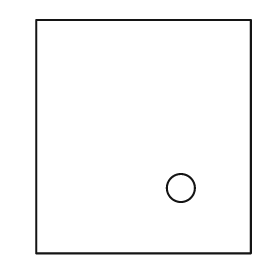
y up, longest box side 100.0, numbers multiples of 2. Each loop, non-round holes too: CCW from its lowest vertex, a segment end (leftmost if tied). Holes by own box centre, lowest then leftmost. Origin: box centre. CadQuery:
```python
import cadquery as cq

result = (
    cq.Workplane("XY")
    .moveTo(-46.0, -50.0)
    .lineTo(46.0, -50.0)
    .lineTo(46.0, 50.0)
    .lineTo(-46.0, 50.0)
    .close()
    .moveTo(16.0, -22.0)
    .circle(6.0)
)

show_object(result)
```